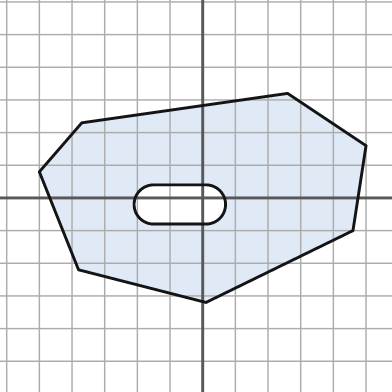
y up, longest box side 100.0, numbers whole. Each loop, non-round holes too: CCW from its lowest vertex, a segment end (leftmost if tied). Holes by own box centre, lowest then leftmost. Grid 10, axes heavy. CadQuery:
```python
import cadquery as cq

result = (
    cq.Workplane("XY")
    .moveTo(1.0, -32.0)
    .lineTo(46.0, -10.0)
    .lineTo(50.0, 16.0)
    .lineTo(26.0, 32.0)
    .lineTo(-37.0, 23.0)
    .lineTo(-50.0, 8.0)
    .lineTo(-38.0, -22.0)
    .close()
    .moveTo(-15.0, -8.0)
    .lineTo(1.0, -8.0)
    .threePointArc((7.0, -2.0), (1.0, 4.0))
    .lineTo(-15.0, 4.0)
    .threePointArc((-21.0, -2.0), (-15.0, -8.0))
    .close()
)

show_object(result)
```